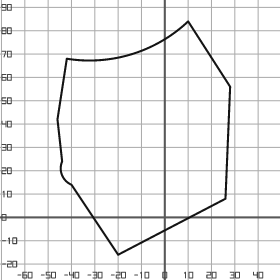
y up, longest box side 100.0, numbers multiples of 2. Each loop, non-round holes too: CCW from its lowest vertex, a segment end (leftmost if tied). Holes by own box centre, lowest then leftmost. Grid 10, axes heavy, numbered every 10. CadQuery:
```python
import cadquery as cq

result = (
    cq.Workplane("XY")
    .moveTo(-20.0, -16.0)
    .lineTo(26.0, 8.0)
    .lineTo(28.0, 56.0)
    .lineTo(10.0, 84.0)
    .threePointArc((-14.0, 70.0), (-42.0, 68.0))
    .lineTo(-46.0, 42.0)
    .lineTo(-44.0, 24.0)
    .threePointArc((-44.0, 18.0), (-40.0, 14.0))
    .close()
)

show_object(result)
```